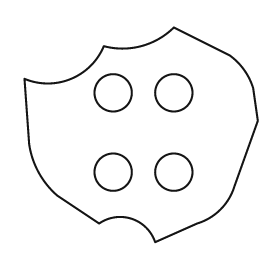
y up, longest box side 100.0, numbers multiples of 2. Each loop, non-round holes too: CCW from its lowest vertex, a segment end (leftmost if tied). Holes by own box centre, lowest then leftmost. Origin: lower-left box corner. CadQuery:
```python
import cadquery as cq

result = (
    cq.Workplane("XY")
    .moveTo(56.0, 0.0)
    .lineTo(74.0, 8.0)
    .threePointArc((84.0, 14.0), (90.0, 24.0))
    .lineTo(100.0, 52.0)
    .lineTo(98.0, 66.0)
    .threePointArc((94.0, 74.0), (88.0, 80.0))
    .lineTo(64.0, 92.0)
    .threePointArc((50.0, 84.0), (34.0, 84.0))
    .threePointArc((20.0, 70.0), (0.0, 70.0))
    .lineTo(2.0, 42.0)
    .threePointArc((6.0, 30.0), (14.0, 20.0))
    .lineTo(32.0, 8.0)
    .threePointArc((46.0, 10.0), (56.0, 0.0))
    .close()
    .moveTo(38.0, 30.0)
    .circle(8.0)
    .moveTo(64.0, 30.0)
    .circle(8.0)
    .moveTo(38.0, 64.0)
    .circle(8.0)
    .moveTo(64.0, 64.0)
    .circle(8.0)
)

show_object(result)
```